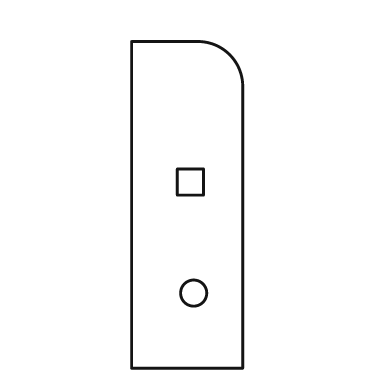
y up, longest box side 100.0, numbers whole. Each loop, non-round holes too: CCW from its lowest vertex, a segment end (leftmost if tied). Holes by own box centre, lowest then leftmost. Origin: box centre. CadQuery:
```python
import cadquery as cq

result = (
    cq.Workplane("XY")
    .moveTo(-17.0, -50.0)
    .lineTo(17.0, -50.0)
    .lineTo(17.0, 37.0)
    .threePointArc((13.0, 46.0), (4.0, 50.0))
    .lineTo(-17.0, 50.0)
    .close()
    .moveTo(2.0, -27.0)
    .circle(4.0)
    .moveTo(-3.0, 3.0)
    .lineTo(5.0, 3.0)
    .lineTo(5.0, 11.0)
    .lineTo(-3.0, 11.0)
    .close()
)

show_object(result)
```